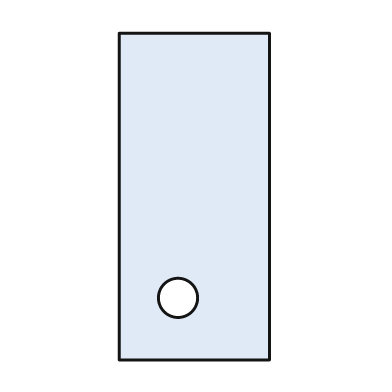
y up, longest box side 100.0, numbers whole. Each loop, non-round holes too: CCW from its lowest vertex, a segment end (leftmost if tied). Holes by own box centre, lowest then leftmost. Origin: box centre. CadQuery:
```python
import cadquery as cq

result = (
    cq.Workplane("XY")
    .moveTo(-23.0, -50.0)
    .lineTo(23.0, -50.0)
    .lineTo(23.0, 50.0)
    .lineTo(-23.0, 50.0)
    .close()
    .moveTo(-5.0, -31.0)
    .circle(6.0)
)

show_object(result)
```